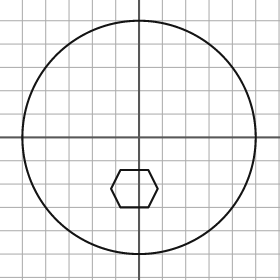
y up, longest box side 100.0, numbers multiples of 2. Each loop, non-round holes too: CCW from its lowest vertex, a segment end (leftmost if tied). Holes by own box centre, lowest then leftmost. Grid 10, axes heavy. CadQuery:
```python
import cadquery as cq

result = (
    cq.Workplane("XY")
    .moveTo(0.0, 0.0)
    .circle(50.0)
    .moveTo(-8.0, -30.0)
    .lineTo(4.0, -30.0)
    .lineTo(8.0, -22.0)
    .lineTo(4.0, -14.0)
    .lineTo(-8.0, -14.0)
    .lineTo(-12.0, -22.0)
    .close()
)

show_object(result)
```